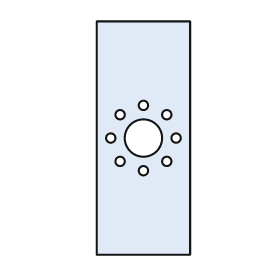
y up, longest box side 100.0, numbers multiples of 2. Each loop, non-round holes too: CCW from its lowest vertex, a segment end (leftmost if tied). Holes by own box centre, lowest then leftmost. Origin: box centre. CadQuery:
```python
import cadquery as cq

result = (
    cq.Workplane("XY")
    .moveTo(-20.0, -50.0)
    .lineTo(20.0, -50.0)
    .lineTo(20.0, 50.0)
    .lineTo(-20.0, 50.0)
    .close()
    .moveTo(0.0, -14.0)
    .circle(2.0)
    .moveTo(-10.0, -10.0)
    .circle(2.0)
    .moveTo(10.0, -10.0)
    .circle(2.0)
    .moveTo(-14.0, 0.0)
    .circle(2.0)
    .moveTo(0.0, 0.0)
    .circle(8.0)
    .moveTo(14.0, 0.0)
    .circle(2.0)
    .moveTo(-10.0, 10.0)
    .circle(2.0)
    .moveTo(10.0, 10.0)
    .circle(2.0)
    .moveTo(0.0, 14.0)
    .circle(2.0)
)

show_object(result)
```